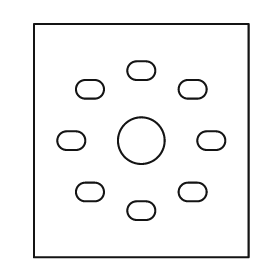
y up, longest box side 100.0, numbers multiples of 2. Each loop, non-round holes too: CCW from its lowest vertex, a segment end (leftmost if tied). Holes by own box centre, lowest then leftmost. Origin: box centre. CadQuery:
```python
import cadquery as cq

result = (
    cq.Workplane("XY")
    .moveTo(-46.0, -50.0)
    .lineTo(46.0, -50.0)
    .lineTo(46.0, 50.0)
    .lineTo(-46.0, 50.0)
    .close()
    .moveTo(-2.0, -34.0)
    .lineTo(2.0, -34.0)
    .threePointArc((6.0, -30.0), (2.0, -26.0))
    .lineTo(-2.0, -26.0)
    .threePointArc((-6.0, -30.0), (-2.0, -34.0))
    .close()
    .moveTo(-24.0, -26.0)
    .lineTo(-20.0, -26.0)
    .threePointArc((-16.0, -22.0), (-20.0, -18.0))
    .lineTo(-24.0, -18.0)
    .threePointArc((-28.0, -22.0), (-24.0, -26.0))
    .close()
    .moveTo(20.0, -26.0)
    .lineTo(24.0, -26.0)
    .threePointArc((28.0, -22.0), (24.0, -18.0))
    .lineTo(20.0, -18.0)
    .threePointArc((16.0, -22.0), (20.0, -26.0))
    .close()
    .moveTo(-32.0, -4.0)
    .lineTo(-28.0, -4.0)
    .threePointArc((-24.0, 0.0), (-28.0, 4.0))
    .lineTo(-32.0, 4.0)
    .threePointArc((-36.0, 0.0), (-32.0, -4.0))
    .close()
    .moveTo(0.0, 0.0)
    .circle(10.0)
    .moveTo(28.0, -4.0)
    .lineTo(32.0, -4.0)
    .threePointArc((36.0, 0.0), (32.0, 4.0))
    .lineTo(28.0, 4.0)
    .threePointArc((24.0, 0.0), (28.0, -4.0))
    .close()
    .moveTo(-24.0, 18.0)
    .lineTo(-20.0, 18.0)
    .threePointArc((-16.0, 22.0), (-20.0, 26.0))
    .lineTo(-24.0, 26.0)
    .threePointArc((-28.0, 22.0), (-24.0, 18.0))
    .close()
    .moveTo(20.0, 18.0)
    .lineTo(24.0, 18.0)
    .threePointArc((28.0, 22.0), (24.0, 26.0))
    .lineTo(20.0, 26.0)
    .threePointArc((16.0, 22.0), (20.0, 18.0))
    .close()
    .moveTo(-2.0, 26.0)
    .lineTo(2.0, 26.0)
    .threePointArc((6.0, 30.0), (2.0, 34.0))
    .lineTo(-2.0, 34.0)
    .threePointArc((-6.0, 30.0), (-2.0, 26.0))
    .close()
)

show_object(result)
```